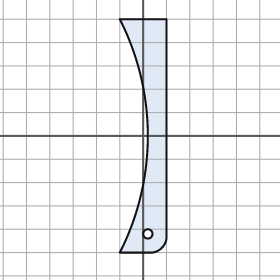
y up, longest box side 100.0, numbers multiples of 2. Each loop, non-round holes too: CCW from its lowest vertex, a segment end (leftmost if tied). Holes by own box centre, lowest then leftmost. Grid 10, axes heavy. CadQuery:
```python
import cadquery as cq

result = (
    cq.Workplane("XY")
    .moveTo(-10.0, -50.0)
    .lineTo(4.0, -50.0)
    .threePointArc((8.0, -48.0), (10.0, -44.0))
    .lineTo(10.0, 50.0)
    .lineTo(-10.0, 50.0)
    .threePointArc((2.0, 0.0), (-10.0, -50.0))
    .close()
    .moveTo(2.0, -42.0)
    .circle(2.0)
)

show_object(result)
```